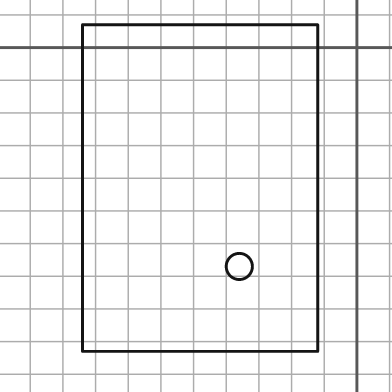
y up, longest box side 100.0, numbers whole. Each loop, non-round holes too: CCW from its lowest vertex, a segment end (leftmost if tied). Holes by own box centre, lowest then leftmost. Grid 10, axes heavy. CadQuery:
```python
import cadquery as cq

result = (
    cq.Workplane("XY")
    .moveTo(-84.0, -93.0)
    .lineTo(-12.0, -93.0)
    .lineTo(-12.0, 7.0)
    .lineTo(-84.0, 7.0)
    .close()
    .moveTo(-36.0, -67.0)
    .circle(4.0)
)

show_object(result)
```